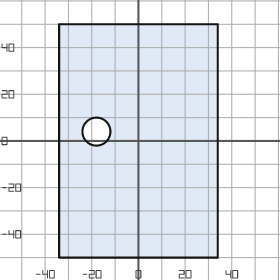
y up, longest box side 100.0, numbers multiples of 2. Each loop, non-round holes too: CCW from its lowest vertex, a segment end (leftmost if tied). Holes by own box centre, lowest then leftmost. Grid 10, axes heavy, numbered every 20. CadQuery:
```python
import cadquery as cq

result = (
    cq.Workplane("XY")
    .moveTo(-34.0, -50.0)
    .lineTo(34.0, -50.0)
    .lineTo(34.0, 50.0)
    .lineTo(-34.0, 50.0)
    .close()
    .moveTo(-18.0, 4.0)
    .circle(6.0)
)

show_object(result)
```